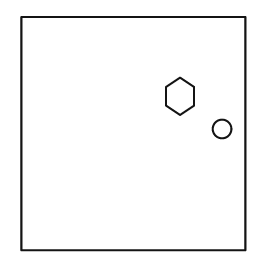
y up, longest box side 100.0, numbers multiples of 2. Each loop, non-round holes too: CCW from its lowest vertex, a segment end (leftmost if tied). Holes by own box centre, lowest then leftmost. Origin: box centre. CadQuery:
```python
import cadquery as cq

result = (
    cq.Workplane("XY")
    .moveTo(-48.0, -50.0)
    .lineTo(48.0, -50.0)
    .lineTo(48.0, 50.0)
    .lineTo(-48.0, 50.0)
    .close()
    .moveTo(38.0, 2.0)
    .circle(4.0)
    .moveTo(20.0, 8.0)
    .lineTo(26.0, 12.0)
    .lineTo(26.0, 20.0)
    .lineTo(20.0, 24.0)
    .lineTo(14.0, 20.0)
    .lineTo(14.0, 12.0)
    .close()
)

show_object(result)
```